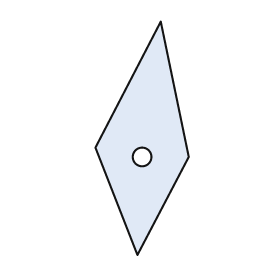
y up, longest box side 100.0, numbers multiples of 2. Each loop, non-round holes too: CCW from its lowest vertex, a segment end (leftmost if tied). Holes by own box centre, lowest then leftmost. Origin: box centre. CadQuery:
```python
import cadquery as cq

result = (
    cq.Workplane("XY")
    .moveTo(-2.0, -50.0)
    .lineTo(20.0, -8.0)
    .lineTo(8.0, 50.0)
    .lineTo(-20.0, -4.0)
    .close()
    .moveTo(0.0, -8.0)
    .circle(4.0)
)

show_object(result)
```